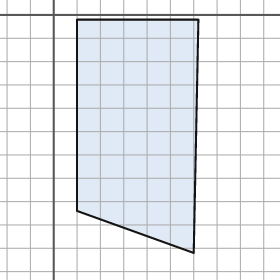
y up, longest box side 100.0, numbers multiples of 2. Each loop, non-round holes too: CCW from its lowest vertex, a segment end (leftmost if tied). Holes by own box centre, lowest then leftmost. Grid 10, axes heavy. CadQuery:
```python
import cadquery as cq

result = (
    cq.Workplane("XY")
    .moveTo(60.0, -102.0)
    .lineTo(62.0, -2.0)
    .lineTo(10.0, -2.0)
    .lineTo(10.0, -84.0)
    .close()
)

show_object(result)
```